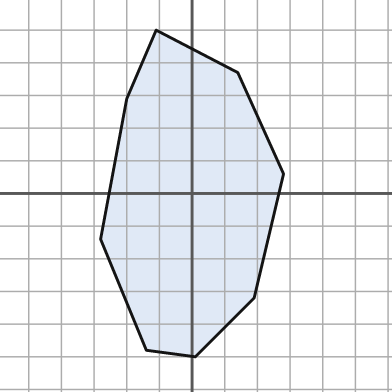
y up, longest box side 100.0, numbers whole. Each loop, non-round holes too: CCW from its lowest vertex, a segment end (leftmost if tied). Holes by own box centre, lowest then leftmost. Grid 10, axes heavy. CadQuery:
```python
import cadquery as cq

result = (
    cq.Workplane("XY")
    .moveTo(1.0, -50.0)
    .lineTo(19.0, -32.0)
    .lineTo(28.0, 6.0)
    .lineTo(14.0, 37.0)
    .lineTo(-11.0, 50.0)
    .lineTo(-20.0, 29.0)
    .lineTo(-28.0, -14.0)
    .lineTo(-14.0, -48.0)
    .close()
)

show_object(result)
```